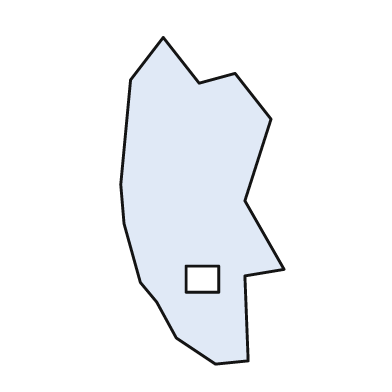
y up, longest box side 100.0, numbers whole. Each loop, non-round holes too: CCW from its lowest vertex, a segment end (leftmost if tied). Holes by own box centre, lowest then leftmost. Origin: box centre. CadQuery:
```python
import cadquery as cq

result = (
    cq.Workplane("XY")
    .moveTo(4.0, -50.0)
    .lineTo(14.0, -49.0)
    .lineTo(13.0, -23.0)
    .lineTo(25.0, -21.0)
    .lineTo(13.0, 0.0)
    .lineTo(21.0, 25.0)
    .lineTo(10.0, 39.0)
    .lineTo(-1.0, 36.0)
    .lineTo(-12.0, 50.0)
    .lineTo(-22.0, 37.0)
    .lineTo(-25.0, 5.0)
    .lineTo(-24.0, -7.0)
    .lineTo(-19.0, -25.0)
    .lineTo(-14.0, -31.0)
    .lineTo(-8.0, -42.0)
    .close()
    .moveTo(-5.0, -28.0)
    .lineTo(5.0, -28.0)
    .lineTo(5.0, -20.0)
    .lineTo(-5.0, -20.0)
    .close()
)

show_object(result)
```